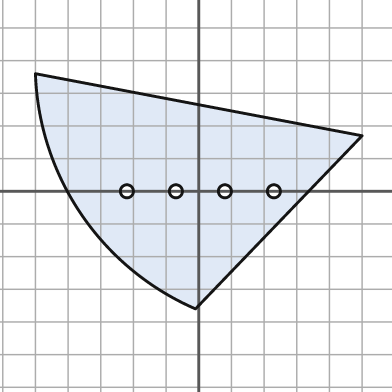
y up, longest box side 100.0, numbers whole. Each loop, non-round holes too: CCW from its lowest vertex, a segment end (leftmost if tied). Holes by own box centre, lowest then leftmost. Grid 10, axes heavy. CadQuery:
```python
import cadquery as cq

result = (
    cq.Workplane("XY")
    .moveTo(-1.0, -36.0)
    .lineTo(50.0, 17.0)
    .lineTo(-50.0, 36.0)
    .threePointArc((-36.0, -7.0), (-1.0, -36.0))
    .close()
    .moveTo(-22.0, 0.0)
    .circle(2.0)
    .moveTo(-7.0, 0.0)
    .circle(2.0)
    .moveTo(8.0, 0.0)
    .circle(2.0)
    .moveTo(23.0, 0.0)
    .circle(2.0)
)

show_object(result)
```